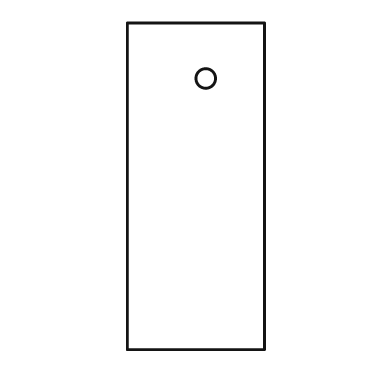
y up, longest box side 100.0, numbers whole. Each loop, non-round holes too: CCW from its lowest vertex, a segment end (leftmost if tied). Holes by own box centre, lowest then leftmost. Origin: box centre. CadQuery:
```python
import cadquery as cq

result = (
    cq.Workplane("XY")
    .moveTo(-21.0, -50.0)
    .lineTo(21.0, -50.0)
    .lineTo(21.0, 50.0)
    .lineTo(-21.0, 50.0)
    .close()
    .moveTo(3.0, 33.0)
    .circle(3.0)
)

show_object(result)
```